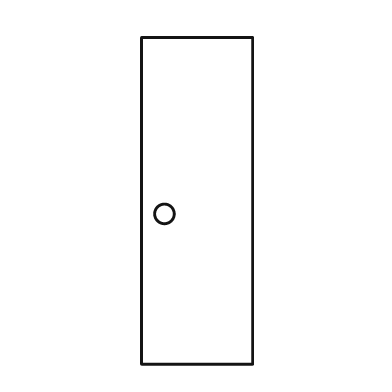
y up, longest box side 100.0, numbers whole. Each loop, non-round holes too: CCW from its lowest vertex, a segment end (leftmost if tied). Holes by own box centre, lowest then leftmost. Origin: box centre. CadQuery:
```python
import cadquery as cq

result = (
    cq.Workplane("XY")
    .moveTo(-17.0, -50.0)
    .lineTo(17.0, -50.0)
    .lineTo(17.0, 50.0)
    .lineTo(-17.0, 50.0)
    .close()
    .moveTo(-10.0, -4.0)
    .circle(3.0)
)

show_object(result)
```